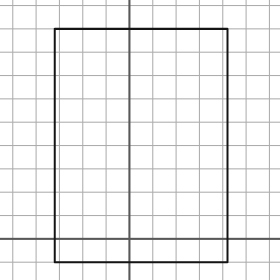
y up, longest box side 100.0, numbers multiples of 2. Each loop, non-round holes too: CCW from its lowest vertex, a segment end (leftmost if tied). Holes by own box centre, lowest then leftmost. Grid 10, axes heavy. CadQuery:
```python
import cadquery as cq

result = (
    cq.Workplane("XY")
    .moveTo(-32.0, -10.0)
    .lineTo(42.0, -10.0)
    .lineTo(42.0, 90.0)
    .lineTo(-32.0, 90.0)
    .close()
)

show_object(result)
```